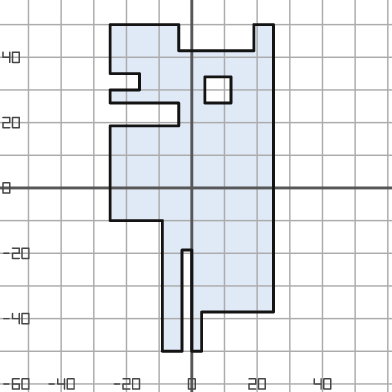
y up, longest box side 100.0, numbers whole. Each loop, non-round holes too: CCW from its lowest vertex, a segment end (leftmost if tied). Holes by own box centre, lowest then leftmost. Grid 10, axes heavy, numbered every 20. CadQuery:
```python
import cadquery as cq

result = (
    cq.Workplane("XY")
    .moveTo(-9.0, -50.0)
    .lineTo(-3.0, -50.0)
    .lineTo(-3.0, -19.0)
    .lineTo(0.0, -19.0)
    .lineTo(0.0, -50.0)
    .lineTo(3.0, -50.0)
    .lineTo(3.0, -38.0)
    .lineTo(25.0, -38.0)
    .lineTo(25.0, 50.0)
    .lineTo(19.0, 50.0)
    .lineTo(19.0, 42.0)
    .lineTo(-4.0, 42.0)
    .lineTo(-4.0, 50.0)
    .lineTo(-25.0, 50.0)
    .lineTo(-25.0, 35.0)
    .lineTo(-16.0, 35.0)
    .lineTo(-16.0, 30.0)
    .lineTo(-25.0, 30.0)
    .lineTo(-25.0, 26.0)
    .lineTo(-4.0, 26.0)
    .lineTo(-4.0, 19.0)
    .lineTo(-25.0, 19.0)
    .lineTo(-25.0, -10.0)
    .lineTo(-9.0, -10.0)
    .close()
    .moveTo(4.0, 26.0)
    .lineTo(12.0, 26.0)
    .lineTo(12.0, 34.0)
    .lineTo(4.0, 34.0)
    .close()
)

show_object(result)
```